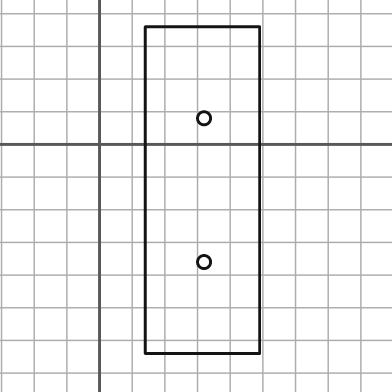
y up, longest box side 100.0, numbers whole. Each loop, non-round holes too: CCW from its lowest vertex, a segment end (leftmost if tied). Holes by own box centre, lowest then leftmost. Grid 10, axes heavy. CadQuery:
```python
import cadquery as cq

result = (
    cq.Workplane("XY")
    .moveTo(14.0, -64.0)
    .lineTo(49.0, -64.0)
    .lineTo(49.0, 36.0)
    .lineTo(14.0, 36.0)
    .close()
    .moveTo(32.0, -36.0)
    .circle(2.0)
    .moveTo(32.0, 8.0)
    .circle(2.0)
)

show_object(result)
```